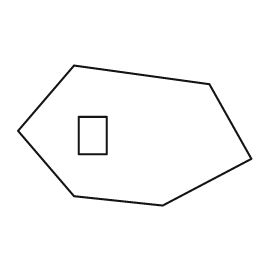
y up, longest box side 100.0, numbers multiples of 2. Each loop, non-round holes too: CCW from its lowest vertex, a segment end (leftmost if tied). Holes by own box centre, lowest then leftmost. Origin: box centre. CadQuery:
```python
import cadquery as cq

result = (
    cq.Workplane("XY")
    .moveTo(12.0, -30.0)
    .lineTo(50.0, -10.0)
    .lineTo(32.0, 22.0)
    .lineTo(-26.0, 30.0)
    .lineTo(-50.0, 2.0)
    .lineTo(-26.0, -26.0)
    .close()
    .moveTo(-24.0, -8.0)
    .lineTo(-12.0, -8.0)
    .lineTo(-12.0, 8.0)
    .lineTo(-24.0, 8.0)
    .close()
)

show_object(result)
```